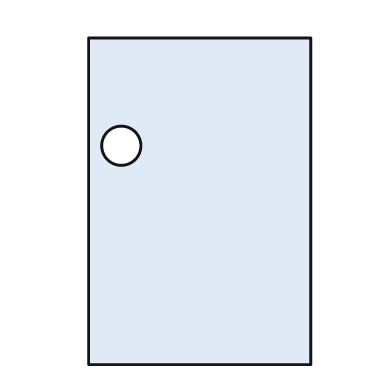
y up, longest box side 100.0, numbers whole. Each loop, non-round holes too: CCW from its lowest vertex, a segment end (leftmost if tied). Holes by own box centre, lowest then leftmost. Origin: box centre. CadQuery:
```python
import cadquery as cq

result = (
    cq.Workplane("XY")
    .moveTo(-34.0, -50.0)
    .lineTo(34.0, -50.0)
    .lineTo(34.0, 50.0)
    .lineTo(-34.0, 50.0)
    .close()
    .moveTo(-24.0, 17.0)
    .circle(6.0)
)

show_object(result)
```